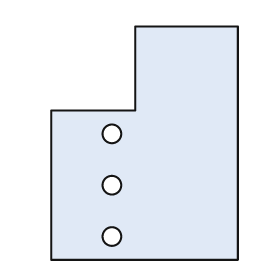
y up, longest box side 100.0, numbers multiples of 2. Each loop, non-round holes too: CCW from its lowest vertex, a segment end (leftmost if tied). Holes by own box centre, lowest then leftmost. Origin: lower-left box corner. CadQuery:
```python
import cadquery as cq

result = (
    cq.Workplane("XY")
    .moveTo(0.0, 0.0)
    .lineTo(80.0, 0.0)
    .lineTo(80.0, 100.0)
    .lineTo(36.0, 100.0)
    .lineTo(36.0, 64.0)
    .lineTo(0.0, 64.0)
    .close()
    .moveTo(26.0, 10.0)
    .circle(4.0)
    .moveTo(26.0, 32.0)
    .circle(4.0)
    .moveTo(26.0, 54.0)
    .circle(4.0)
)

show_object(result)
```